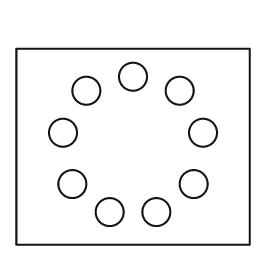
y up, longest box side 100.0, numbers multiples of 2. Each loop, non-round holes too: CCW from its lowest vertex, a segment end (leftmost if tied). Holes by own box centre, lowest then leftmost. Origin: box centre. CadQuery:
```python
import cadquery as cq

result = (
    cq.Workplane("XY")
    .moveTo(-50.0, -42.0)
    .lineTo(50.0, -42.0)
    .lineTo(50.0, 42.0)
    .lineTo(-50.0, 42.0)
    .close()
    .moveTo(-10.0, -28.0)
    .circle(6.0)
    .moveTo(10.0, -28.0)
    .circle(6.0)
    .moveTo(-26.0, -16.0)
    .circle(6.0)
    .moveTo(26.0, -16.0)
    .circle(6.0)
    .moveTo(-30.0, 6.0)
    .circle(6.0)
    .moveTo(30.0, 6.0)
    .circle(6.0)
    .moveTo(-20.0, 24.0)
    .circle(6.0)
    .moveTo(20.0, 24.0)
    .circle(6.0)
    .moveTo(0.0, 30.0)
    .circle(6.0)
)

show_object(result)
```